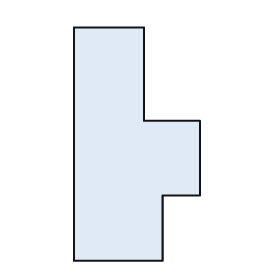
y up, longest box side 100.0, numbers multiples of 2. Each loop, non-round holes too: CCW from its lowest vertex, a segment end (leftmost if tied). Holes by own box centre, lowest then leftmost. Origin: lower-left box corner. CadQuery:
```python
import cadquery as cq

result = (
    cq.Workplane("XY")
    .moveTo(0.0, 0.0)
    .lineTo(38.0, 0.0)
    .lineTo(38.0, 28.0)
    .lineTo(54.0, 28.0)
    .lineTo(54.0, 60.0)
    .lineTo(30.0, 60.0)
    .lineTo(30.0, 100.0)
    .lineTo(0.0, 100.0)
    .close()
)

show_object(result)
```